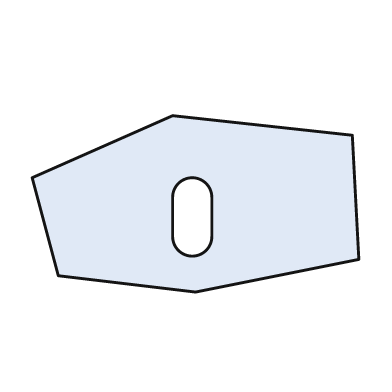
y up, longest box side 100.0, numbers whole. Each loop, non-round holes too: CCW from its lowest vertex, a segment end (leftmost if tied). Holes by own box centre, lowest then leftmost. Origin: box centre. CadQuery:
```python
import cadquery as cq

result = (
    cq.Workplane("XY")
    .moveTo(0.0, -27.0)
    .lineTo(50.0, -17.0)
    .lineTo(48.0, 21.0)
    .lineTo(-7.0, 27.0)
    .lineTo(-50.0, 8.0)
    .lineTo(-42.0, -22.0)
    .close()
    .moveTo(-7.0, -10.0)
    .threePointArc((-1.0, -16.0), (5.0, -10.0))
    .lineTo(5.0, 2.0)
    .threePointArc((-1.0, 8.0), (-7.0, 2.0))
    .close()
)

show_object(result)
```